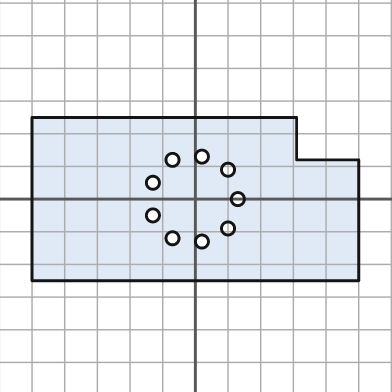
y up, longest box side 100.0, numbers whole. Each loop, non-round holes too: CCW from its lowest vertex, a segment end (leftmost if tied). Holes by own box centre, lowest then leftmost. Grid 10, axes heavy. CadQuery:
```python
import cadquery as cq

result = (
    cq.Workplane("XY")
    .moveTo(-50.0, -25.0)
    .lineTo(50.0, -25.0)
    .lineTo(50.0, 12.0)
    .lineTo(31.0, 12.0)
    .lineTo(31.0, 25.0)
    .lineTo(-50.0, 25.0)
    .close()
    .moveTo(2.0, -13.0)
    .circle(2.0)
    .moveTo(-7.0, -12.0)
    .circle(2.0)
    .moveTo(10.0, -9.0)
    .circle(2.0)
    .moveTo(-13.0, -5.0)
    .circle(2.0)
    .moveTo(13.0, 0.0)
    .circle(2.0)
    .moveTo(-13.0, 5.0)
    .circle(2.0)
    .moveTo(10.0, 9.0)
    .circle(2.0)
    .moveTo(-7.0, 12.0)
    .circle(2.0)
    .moveTo(2.0, 13.0)
    .circle(2.0)
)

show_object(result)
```